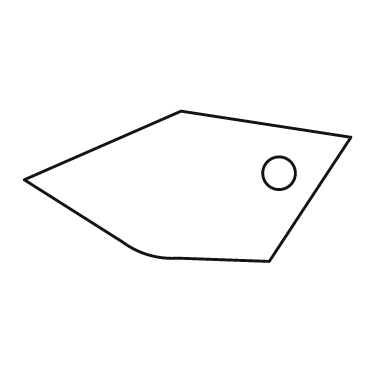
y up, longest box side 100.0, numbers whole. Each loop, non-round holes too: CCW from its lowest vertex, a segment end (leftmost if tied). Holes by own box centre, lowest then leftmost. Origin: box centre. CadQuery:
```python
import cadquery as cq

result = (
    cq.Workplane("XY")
    .moveTo(25.0, -23.0)
    .lineTo(50.0, 15.0)
    .lineTo(-2.0, 23.0)
    .lineTo(-50.0, 2.0)
    .lineTo(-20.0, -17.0)
    .threePointArc((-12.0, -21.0), (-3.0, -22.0))
    .close()
    .moveTo(28.0, 4.0)
    .circle(5.0)
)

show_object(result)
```